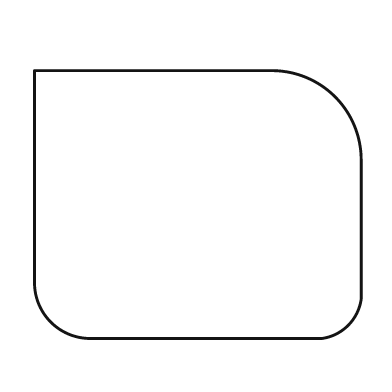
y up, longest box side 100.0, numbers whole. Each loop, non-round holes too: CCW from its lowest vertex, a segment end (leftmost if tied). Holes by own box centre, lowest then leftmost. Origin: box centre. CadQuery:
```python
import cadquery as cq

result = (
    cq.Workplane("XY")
    .moveTo(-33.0, -41.0)
    .lineTo(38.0, -41.0)
    .threePointArc((46.0, -37.0), (50.0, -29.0))
    .lineTo(50.0, 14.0)
    .threePointArc((42.0, 33.0), (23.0, 41.0))
    .lineTo(-50.0, 41.0)
    .lineTo(-50.0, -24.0)
    .threePointArc((-45.0, -36.0), (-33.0, -41.0))
    .close()
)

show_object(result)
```